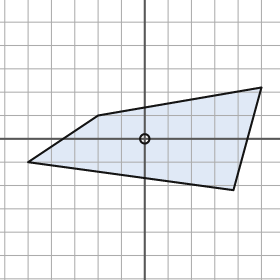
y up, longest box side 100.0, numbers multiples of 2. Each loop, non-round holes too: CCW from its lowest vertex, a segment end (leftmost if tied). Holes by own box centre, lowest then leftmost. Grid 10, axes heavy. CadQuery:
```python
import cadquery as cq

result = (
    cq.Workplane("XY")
    .moveTo(38.0, -22.0)
    .lineTo(50.0, 22.0)
    .lineTo(-20.0, 10.0)
    .lineTo(-50.0, -10.0)
    .close()
    .moveTo(0.0, 0.0)
    .circle(2.0)
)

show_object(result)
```